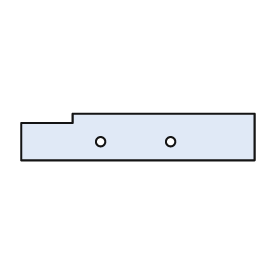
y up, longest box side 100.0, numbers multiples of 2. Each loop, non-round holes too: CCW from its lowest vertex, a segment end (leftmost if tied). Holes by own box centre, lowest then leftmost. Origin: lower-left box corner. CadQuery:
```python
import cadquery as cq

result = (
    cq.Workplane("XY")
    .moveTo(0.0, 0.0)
    .lineTo(100.0, 0.0)
    .lineTo(100.0, 20.0)
    .lineTo(22.0, 20.0)
    .lineTo(22.0, 16.0)
    .lineTo(0.0, 16.0)
    .close()
    .moveTo(34.0, 8.0)
    .circle(2.0)
    .moveTo(64.0, 8.0)
    .circle(2.0)
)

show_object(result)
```